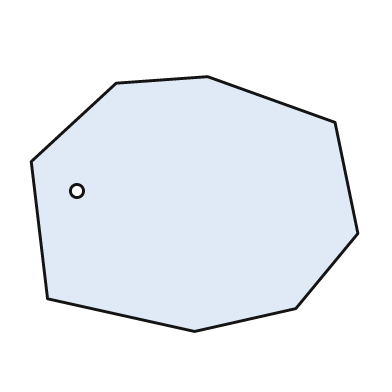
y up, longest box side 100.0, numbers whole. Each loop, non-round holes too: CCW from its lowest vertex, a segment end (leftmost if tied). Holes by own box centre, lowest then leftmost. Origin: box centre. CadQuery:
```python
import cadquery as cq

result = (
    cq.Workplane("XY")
    .moveTo(0.0, -39.0)
    .lineTo(31.0, -32.0)
    .lineTo(50.0, -9.0)
    .lineTo(43.0, 25.0)
    .lineTo(4.0, 39.0)
    .lineTo(-24.0, 37.0)
    .lineTo(-50.0, 13.0)
    .lineTo(-45.0, -29.0)
    .close()
    .moveTo(-36.0, 4.0)
    .circle(2.0)
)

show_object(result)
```